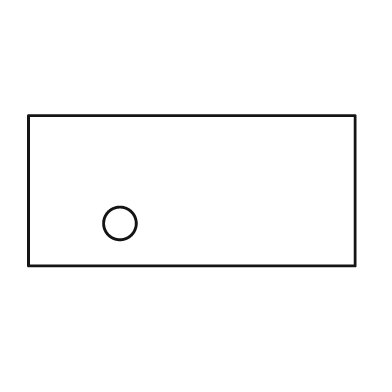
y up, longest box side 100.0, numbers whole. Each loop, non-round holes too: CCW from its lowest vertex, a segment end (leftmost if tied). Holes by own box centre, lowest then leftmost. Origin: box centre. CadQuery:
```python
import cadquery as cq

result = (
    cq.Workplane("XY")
    .moveTo(-50.0, -23.0)
    .lineTo(50.0, -23.0)
    .lineTo(50.0, 23.0)
    .lineTo(-50.0, 23.0)
    .close()
    .moveTo(-22.0, -10.0)
    .circle(5.0)
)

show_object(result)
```